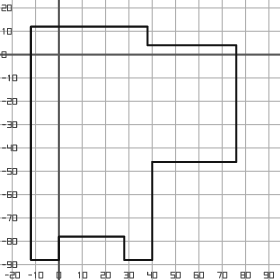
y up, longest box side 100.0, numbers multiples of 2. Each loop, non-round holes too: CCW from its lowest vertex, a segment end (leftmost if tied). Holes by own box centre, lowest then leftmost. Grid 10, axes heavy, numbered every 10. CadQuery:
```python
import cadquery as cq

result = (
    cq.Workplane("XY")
    .moveTo(-12.0, -88.0)
    .lineTo(0.0, -88.0)
    .lineTo(0.0, -78.0)
    .lineTo(28.0, -78.0)
    .lineTo(28.0, -88.0)
    .lineTo(40.0, -88.0)
    .lineTo(40.0, -46.0)
    .lineTo(76.0, -46.0)
    .lineTo(76.0, 4.0)
    .lineTo(38.0, 4.0)
    .lineTo(38.0, 12.0)
    .lineTo(-12.0, 12.0)
    .close()
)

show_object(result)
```